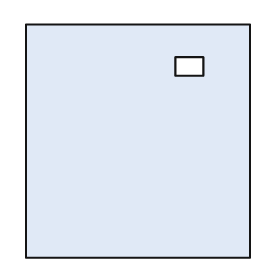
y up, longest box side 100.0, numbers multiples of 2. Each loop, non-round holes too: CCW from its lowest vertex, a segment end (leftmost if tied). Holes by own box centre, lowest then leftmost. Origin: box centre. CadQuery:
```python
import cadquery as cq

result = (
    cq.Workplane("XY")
    .moveTo(-48.0, -50.0)
    .lineTo(48.0, -50.0)
    .lineTo(48.0, 50.0)
    .lineTo(-48.0, 50.0)
    .close()
    .moveTo(16.0, 28.0)
    .lineTo(28.0, 28.0)
    .lineTo(28.0, 36.0)
    .lineTo(16.0, 36.0)
    .close()
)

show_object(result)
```